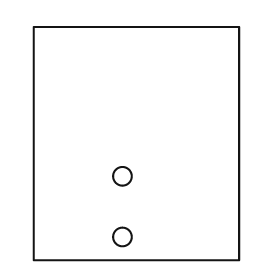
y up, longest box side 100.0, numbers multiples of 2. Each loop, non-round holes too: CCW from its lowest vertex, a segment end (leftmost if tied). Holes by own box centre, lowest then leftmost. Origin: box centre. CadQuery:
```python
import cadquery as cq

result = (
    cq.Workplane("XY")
    .moveTo(-44.0, -50.0)
    .lineTo(44.0, -50.0)
    .lineTo(44.0, 50.0)
    .lineTo(-44.0, 50.0)
    .close()
    .moveTo(-6.0, -40.0)
    .circle(4.0)
    .moveTo(-6.0, -14.0)
    .circle(4.0)
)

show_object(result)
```